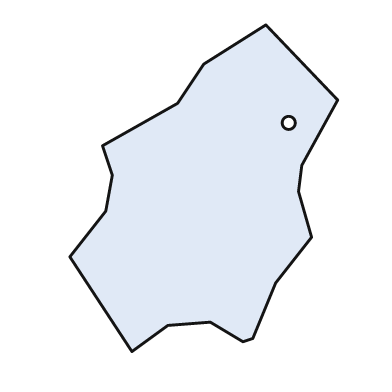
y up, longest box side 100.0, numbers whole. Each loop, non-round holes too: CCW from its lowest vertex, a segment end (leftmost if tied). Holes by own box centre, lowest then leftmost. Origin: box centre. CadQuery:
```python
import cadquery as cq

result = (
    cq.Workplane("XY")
    .moveTo(-22.0, -50.0)
    .lineTo(-11.0, -42.0)
    .lineTo(2.0, -41.0)
    .lineTo(12.0, -47.0)
    .lineTo(15.0, -46.0)
    .lineTo(22.0, -29.0)
    .lineTo(33.0, -15.0)
    .lineTo(29.0, -1.0)
    .lineTo(30.0, 7.0)
    .lineTo(41.0, 27.0)
    .lineTo(19.0, 50.0)
    .lineTo(0.0, 38.0)
    .lineTo(-8.0, 26.0)
    .lineTo(-31.0, 13.0)
    .lineTo(-28.0, 4.0)
    .lineTo(-30.0, -7.0)
    .lineTo(-41.0, -21.0)
    .close()
    .moveTo(26.0, 20.0)
    .circle(2.0)
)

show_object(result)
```